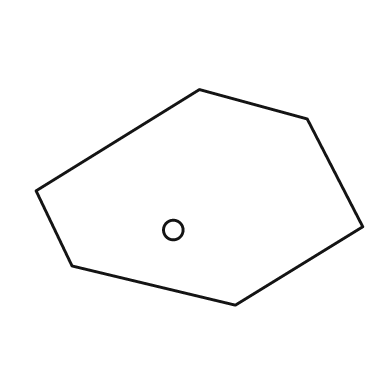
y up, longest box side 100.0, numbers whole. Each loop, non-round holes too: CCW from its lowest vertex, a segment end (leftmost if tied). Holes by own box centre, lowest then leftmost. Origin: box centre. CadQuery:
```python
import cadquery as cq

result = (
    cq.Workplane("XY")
    .moveTo(11.0, -33.0)
    .lineTo(50.0, -9.0)
    .lineTo(33.0, 24.0)
    .lineTo(0.0, 33.0)
    .lineTo(-50.0, 2.0)
    .lineTo(-39.0, -21.0)
    .close()
    .moveTo(-8.0, -10.0)
    .circle(3.0)
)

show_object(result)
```